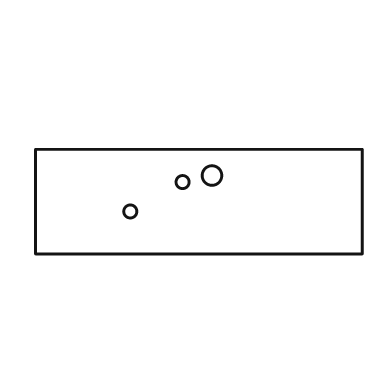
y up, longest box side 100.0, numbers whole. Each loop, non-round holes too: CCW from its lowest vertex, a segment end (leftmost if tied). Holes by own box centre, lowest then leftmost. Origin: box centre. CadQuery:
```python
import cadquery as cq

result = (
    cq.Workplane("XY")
    .moveTo(-50.0, -16.0)
    .lineTo(50.0, -16.0)
    .lineTo(50.0, 16.0)
    .lineTo(-50.0, 16.0)
    .close()
    .moveTo(-21.0, -3.0)
    .circle(2.0)
    .moveTo(-5.0, 6.0)
    .circle(2.0)
    .moveTo(4.0, 8.0)
    .circle(3.0)
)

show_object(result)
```